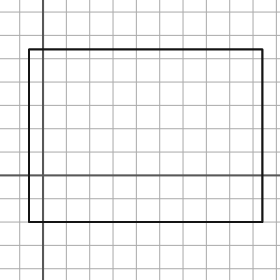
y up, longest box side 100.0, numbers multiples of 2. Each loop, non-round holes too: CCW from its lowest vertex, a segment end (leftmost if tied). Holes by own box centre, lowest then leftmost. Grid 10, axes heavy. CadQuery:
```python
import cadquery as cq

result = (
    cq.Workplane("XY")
    .moveTo(-6.0, -20.0)
    .lineTo(94.0, -20.0)
    .lineTo(94.0, 54.0)
    .lineTo(-6.0, 54.0)
    .close()
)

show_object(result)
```